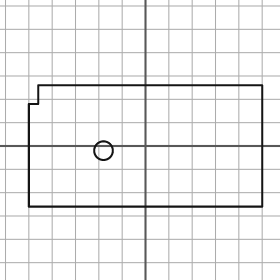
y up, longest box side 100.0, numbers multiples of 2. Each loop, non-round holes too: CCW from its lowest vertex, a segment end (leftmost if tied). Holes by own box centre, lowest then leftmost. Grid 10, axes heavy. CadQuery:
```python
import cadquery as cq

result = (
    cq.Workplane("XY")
    .moveTo(-50.0, -26.0)
    .lineTo(50.0, -26.0)
    .lineTo(50.0, 26.0)
    .lineTo(-46.0, 26.0)
    .lineTo(-46.0, 18.0)
    .lineTo(-50.0, 18.0)
    .close()
    .moveTo(-18.0, -2.0)
    .circle(4.0)
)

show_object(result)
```